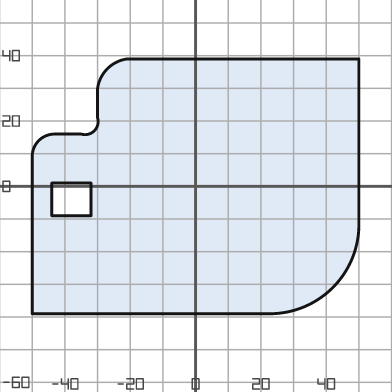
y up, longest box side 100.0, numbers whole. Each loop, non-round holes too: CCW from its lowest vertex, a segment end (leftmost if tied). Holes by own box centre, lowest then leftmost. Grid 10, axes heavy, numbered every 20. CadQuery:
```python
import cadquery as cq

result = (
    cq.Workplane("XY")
    .moveTo(-50.0, -39.0)
    .lineTo(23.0, -39.0)
    .threePointArc((42.0, -31.0), (50.0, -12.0))
    .lineTo(50.0, 39.0)
    .lineTo(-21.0, 39.0)
    .threePointArc((-27.0, 36.0), (-30.0, 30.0))
    .lineTo(-30.0, 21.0)
    .threePointArc((-31.0, 17.0), (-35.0, 16.0))
    .lineTo(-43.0, 16.0)
    .threePointArc((-48.0, 14.0), (-50.0, 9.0))
    .close()
    .moveTo(-44.0, -9.0)
    .lineTo(-32.0, -9.0)
    .lineTo(-32.0, 1.0)
    .lineTo(-44.0, 1.0)
    .close()
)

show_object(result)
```